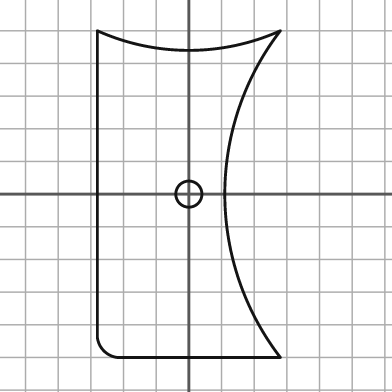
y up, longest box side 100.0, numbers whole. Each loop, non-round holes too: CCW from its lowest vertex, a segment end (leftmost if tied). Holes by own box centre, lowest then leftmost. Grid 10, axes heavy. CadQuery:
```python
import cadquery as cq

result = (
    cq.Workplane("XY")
    .moveTo(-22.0, -50.0)
    .lineTo(28.0, -50.0)
    .threePointArc((11.0, 0.0), (28.0, 50.0))
    .threePointArc((0.0, 44.0), (-28.0, 50.0))
    .lineTo(-28.0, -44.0)
    .threePointArc((-26.0, -48.0), (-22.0, -50.0))
    .close()
    .moveTo(0.0, 0.0)
    .circle(4.0)
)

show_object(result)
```